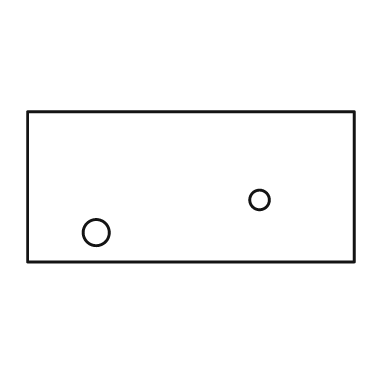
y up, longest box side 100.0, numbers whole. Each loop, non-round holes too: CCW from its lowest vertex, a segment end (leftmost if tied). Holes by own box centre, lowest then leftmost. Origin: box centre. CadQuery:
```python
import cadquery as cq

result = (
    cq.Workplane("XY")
    .moveTo(-50.0, -23.0)
    .lineTo(50.0, -23.0)
    .lineTo(50.0, 23.0)
    .lineTo(-50.0, 23.0)
    .close()
    .moveTo(-29.0, -14.0)
    .circle(4.0)
    .moveTo(21.0, -4.0)
    .circle(3.0)
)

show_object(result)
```